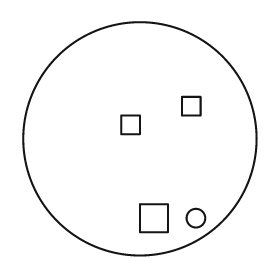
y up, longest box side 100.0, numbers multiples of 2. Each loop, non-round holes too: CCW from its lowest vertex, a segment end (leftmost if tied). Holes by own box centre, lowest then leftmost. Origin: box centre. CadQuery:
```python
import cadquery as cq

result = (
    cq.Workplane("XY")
    .moveTo(0.0, 0.0)
    .circle(50.0)
    .moveTo(0.0, -40.0)
    .lineTo(12.0, -40.0)
    .lineTo(12.0, -28.0)
    .lineTo(0.0, -28.0)
    .close()
    .moveTo(24.0, -34.0)
    .circle(4.0)
    .moveTo(-8.0, 2.0)
    .lineTo(0.0, 2.0)
    .lineTo(0.0, 10.0)
    .lineTo(-8.0, 10.0)
    .close()
    .moveTo(18.0, 10.0)
    .lineTo(26.0, 10.0)
    .lineTo(26.0, 18.0)
    .lineTo(18.0, 18.0)
    .close()
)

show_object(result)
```